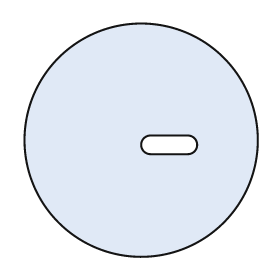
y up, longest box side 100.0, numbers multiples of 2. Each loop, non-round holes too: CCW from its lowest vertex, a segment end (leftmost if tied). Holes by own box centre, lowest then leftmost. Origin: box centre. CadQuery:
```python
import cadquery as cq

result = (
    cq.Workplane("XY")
    .moveTo(0.0, 0.0)
    .circle(50.0)
    .moveTo(4.0, -6.0)
    .lineTo(20.0, -6.0)
    .threePointArc((24.0, -2.0), (20.0, 2.0))
    .lineTo(4.0, 2.0)
    .threePointArc((0.0, -2.0), (4.0, -6.0))
    .close()
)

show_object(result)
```